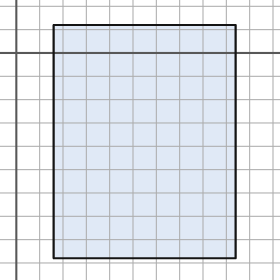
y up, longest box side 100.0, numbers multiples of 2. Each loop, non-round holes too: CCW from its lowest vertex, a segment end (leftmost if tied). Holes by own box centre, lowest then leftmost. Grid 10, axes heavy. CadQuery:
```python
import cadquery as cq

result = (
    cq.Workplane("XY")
    .moveTo(16.0, -88.0)
    .lineTo(94.0, -88.0)
    .lineTo(94.0, 12.0)
    .lineTo(16.0, 12.0)
    .close()
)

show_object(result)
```